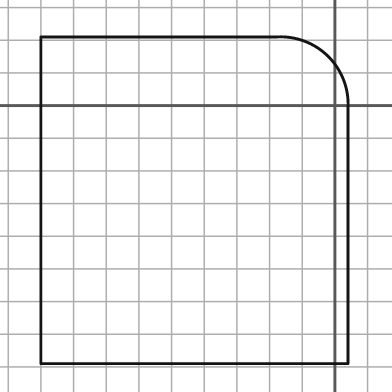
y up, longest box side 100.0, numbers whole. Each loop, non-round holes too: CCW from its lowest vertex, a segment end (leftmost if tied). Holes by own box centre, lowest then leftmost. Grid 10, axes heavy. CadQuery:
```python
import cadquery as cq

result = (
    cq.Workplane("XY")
    .moveTo(-90.0, -79.0)
    .lineTo(4.0, -79.0)
    .lineTo(4.0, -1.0)
    .threePointArc((-2.0, 15.0), (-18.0, 21.0))
    .lineTo(-90.0, 21.0)
    .close()
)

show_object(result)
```